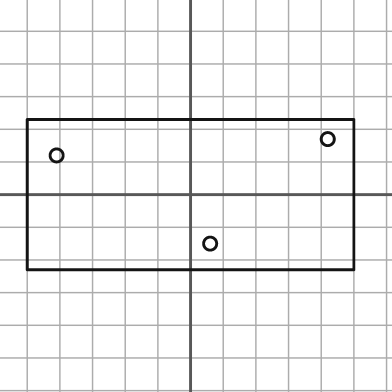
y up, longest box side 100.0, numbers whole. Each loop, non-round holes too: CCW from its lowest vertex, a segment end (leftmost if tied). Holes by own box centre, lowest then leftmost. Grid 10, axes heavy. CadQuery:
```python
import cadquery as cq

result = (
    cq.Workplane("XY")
    .moveTo(-50.0, -23.0)
    .lineTo(50.0, -23.0)
    .lineTo(50.0, 23.0)
    .lineTo(-50.0, 23.0)
    .close()
    .moveTo(6.0, -15.0)
    .circle(2.0)
    .moveTo(-41.0, 12.0)
    .circle(2.0)
    .moveTo(42.0, 17.0)
    .circle(2.0)
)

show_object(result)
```